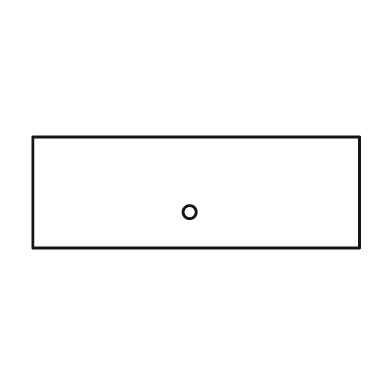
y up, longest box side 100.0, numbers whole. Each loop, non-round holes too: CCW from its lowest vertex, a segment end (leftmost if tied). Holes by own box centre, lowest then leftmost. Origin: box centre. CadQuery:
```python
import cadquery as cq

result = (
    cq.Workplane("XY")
    .moveTo(-50.0, -17.0)
    .lineTo(50.0, -17.0)
    .lineTo(50.0, 17.0)
    .lineTo(-50.0, 17.0)
    .close()
    .moveTo(-2.0, -6.0)
    .circle(2.0)
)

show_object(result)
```